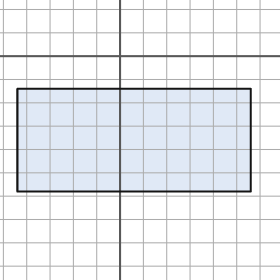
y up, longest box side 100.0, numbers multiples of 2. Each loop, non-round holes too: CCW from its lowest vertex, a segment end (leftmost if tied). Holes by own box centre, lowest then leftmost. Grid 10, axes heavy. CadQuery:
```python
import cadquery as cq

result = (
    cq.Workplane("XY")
    .moveTo(-44.0, -58.0)
    .lineTo(56.0, -58.0)
    .lineTo(56.0, -14.0)
    .lineTo(-44.0, -14.0)
    .close()
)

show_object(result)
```